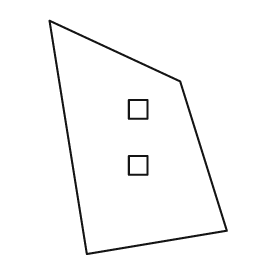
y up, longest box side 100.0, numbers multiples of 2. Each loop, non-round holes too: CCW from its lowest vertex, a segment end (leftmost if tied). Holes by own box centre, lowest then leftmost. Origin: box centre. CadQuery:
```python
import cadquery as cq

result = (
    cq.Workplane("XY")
    .moveTo(-22.0, -50.0)
    .lineTo(38.0, -40.0)
    .lineTo(18.0, 24.0)
    .lineTo(-38.0, 50.0)
    .close()
    .moveTo(-4.0, -16.0)
    .lineTo(4.0, -16.0)
    .lineTo(4.0, -8.0)
    .lineTo(-4.0, -8.0)
    .close()
    .moveTo(-4.0, 8.0)
    .lineTo(4.0, 8.0)
    .lineTo(4.0, 16.0)
    .lineTo(-4.0, 16.0)
    .close()
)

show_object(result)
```